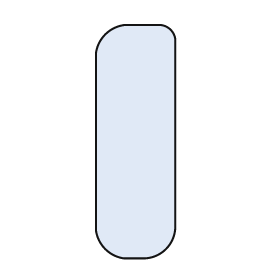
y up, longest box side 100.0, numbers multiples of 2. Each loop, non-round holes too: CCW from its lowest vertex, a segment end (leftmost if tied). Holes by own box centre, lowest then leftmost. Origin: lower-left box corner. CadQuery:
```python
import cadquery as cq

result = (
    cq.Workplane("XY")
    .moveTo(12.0, 0.0)
    .lineTo(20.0, 0.0)
    .threePointArc((30.0, 4.0), (34.0, 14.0))
    .lineTo(34.0, 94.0)
    .threePointArc((32.0, 98.0), (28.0, 100.0))
    .lineTo(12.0, 100.0)
    .threePointArc((4.0, 96.0), (0.0, 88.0))
    .lineTo(0.0, 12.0)
    .threePointArc((4.0, 4.0), (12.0, 0.0))
    .close()
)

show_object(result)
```